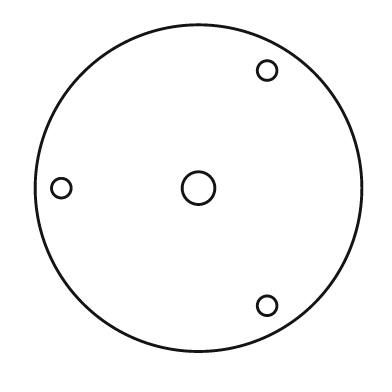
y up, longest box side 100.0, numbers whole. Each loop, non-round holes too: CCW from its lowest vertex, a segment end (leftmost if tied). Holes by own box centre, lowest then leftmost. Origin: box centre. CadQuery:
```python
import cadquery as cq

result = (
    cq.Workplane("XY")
    .moveTo(0.0, 0.0)
    .circle(50.0)
    .moveTo(21.0, -36.0)
    .circle(3.0)
    .moveTo(-42.0, 0.0)
    .circle(3.0)
    .moveTo(0.0, 0.0)
    .circle(5.0)
    .moveTo(21.0, 36.0)
    .circle(3.0)
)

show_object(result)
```